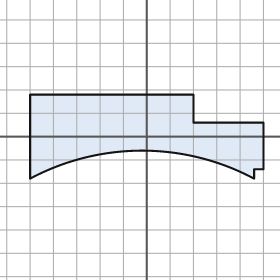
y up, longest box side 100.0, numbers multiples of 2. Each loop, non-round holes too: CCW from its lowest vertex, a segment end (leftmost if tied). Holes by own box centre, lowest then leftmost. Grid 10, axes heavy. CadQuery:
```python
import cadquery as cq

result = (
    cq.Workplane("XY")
    .moveTo(-50.0, -18.0)
    .threePointArc((-2.0, -6.0), (46.0, -18.0))
    .lineTo(46.0, -14.0)
    .lineTo(50.0, -14.0)
    .lineTo(50.0, 6.0)
    .lineTo(20.0, 6.0)
    .lineTo(20.0, 18.0)
    .lineTo(-50.0, 18.0)
    .close()
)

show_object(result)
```